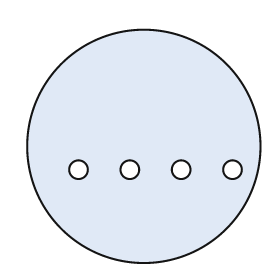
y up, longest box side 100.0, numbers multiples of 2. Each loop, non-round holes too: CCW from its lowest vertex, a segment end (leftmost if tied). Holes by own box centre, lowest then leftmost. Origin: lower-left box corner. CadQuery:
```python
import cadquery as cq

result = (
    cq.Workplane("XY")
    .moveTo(50.0, 50.0)
    .circle(50.0)
    .moveTo(22.0, 40.0)
    .circle(4.0)
    .moveTo(44.0, 40.0)
    .circle(4.0)
    .moveTo(66.0, 40.0)
    .circle(4.0)
    .moveTo(88.0, 40.0)
    .circle(4.0)
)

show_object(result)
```